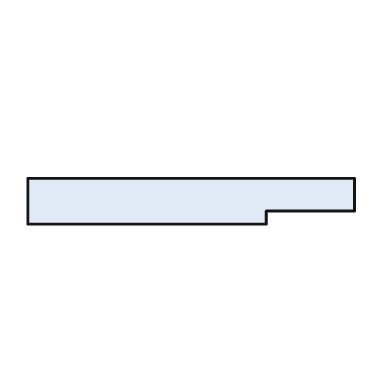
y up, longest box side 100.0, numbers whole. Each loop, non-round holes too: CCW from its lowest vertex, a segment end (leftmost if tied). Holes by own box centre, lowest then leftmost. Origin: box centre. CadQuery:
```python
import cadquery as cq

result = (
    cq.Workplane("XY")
    .moveTo(-50.0, -7.0)
    .lineTo(23.0, -7.0)
    .lineTo(23.0, -3.0)
    .lineTo(50.0, -3.0)
    .lineTo(50.0, 7.0)
    .lineTo(-50.0, 7.0)
    .close()
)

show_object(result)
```